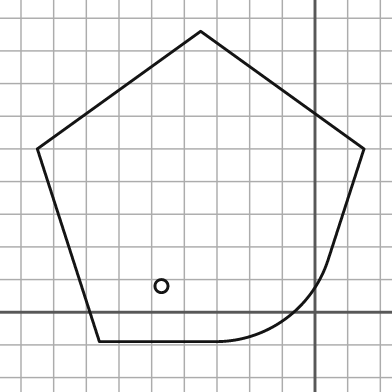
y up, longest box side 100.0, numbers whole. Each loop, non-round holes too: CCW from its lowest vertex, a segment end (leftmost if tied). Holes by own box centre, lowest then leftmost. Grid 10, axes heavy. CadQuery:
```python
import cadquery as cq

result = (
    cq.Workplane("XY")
    .moveTo(-66.0, -9.0)
    .lineTo(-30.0, -9.0)
    .threePointArc((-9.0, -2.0), (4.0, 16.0))
    .lineTo(15.0, 50.0)
    .lineTo(-35.0, 86.0)
    .lineTo(-85.0, 50.0)
    .close()
    .moveTo(-47.0, 8.0)
    .circle(2.0)
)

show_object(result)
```